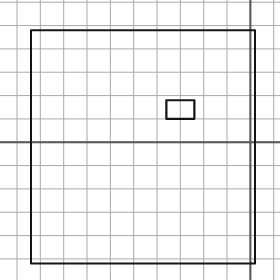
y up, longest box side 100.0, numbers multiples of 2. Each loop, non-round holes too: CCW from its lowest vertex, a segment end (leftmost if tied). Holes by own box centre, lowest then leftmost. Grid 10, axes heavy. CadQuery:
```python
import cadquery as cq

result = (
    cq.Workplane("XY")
    .moveTo(-94.0, -52.0)
    .lineTo(2.0, -52.0)
    .lineTo(2.0, 48.0)
    .lineTo(-94.0, 48.0)
    .close()
    .moveTo(-36.0, 10.0)
    .lineTo(-24.0, 10.0)
    .lineTo(-24.0, 18.0)
    .lineTo(-36.0, 18.0)
    .close()
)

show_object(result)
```